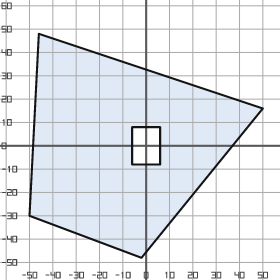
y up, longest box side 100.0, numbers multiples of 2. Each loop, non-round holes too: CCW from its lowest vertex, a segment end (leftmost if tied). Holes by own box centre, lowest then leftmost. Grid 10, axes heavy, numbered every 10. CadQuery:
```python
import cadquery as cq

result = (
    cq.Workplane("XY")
    .moveTo(-2.0, -48.0)
    .lineTo(50.0, 16.0)
    .lineTo(-46.0, 48.0)
    .lineTo(-50.0, -30.0)
    .close()
    .moveTo(-6.0, -8.0)
    .lineTo(6.0, -8.0)
    .lineTo(6.0, 8.0)
    .lineTo(-6.0, 8.0)
    .close()
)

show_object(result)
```